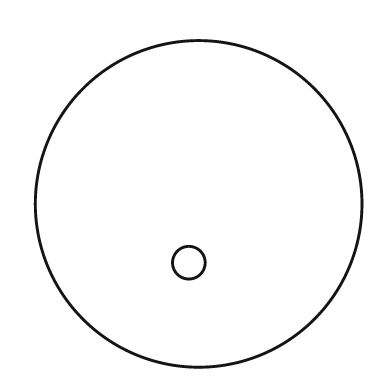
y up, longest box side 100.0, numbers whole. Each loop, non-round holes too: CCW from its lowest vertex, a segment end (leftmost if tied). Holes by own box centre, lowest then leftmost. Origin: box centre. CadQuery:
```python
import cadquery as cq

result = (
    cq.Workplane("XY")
    .moveTo(0.0, 0.0)
    .circle(50.0)
    .moveTo(-3.0, -18.0)
    .circle(5.0)
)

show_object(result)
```